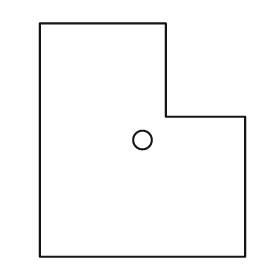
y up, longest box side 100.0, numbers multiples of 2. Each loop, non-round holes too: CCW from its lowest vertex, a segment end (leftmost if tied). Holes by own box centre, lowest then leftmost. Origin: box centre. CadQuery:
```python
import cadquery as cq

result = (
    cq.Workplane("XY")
    .moveTo(-44.0, -50.0)
    .lineTo(44.0, -50.0)
    .lineTo(44.0, 10.0)
    .lineTo(10.0, 10.0)
    .lineTo(10.0, 50.0)
    .lineTo(-44.0, 50.0)
    .close()
    .moveTo(0.0, 0.0)
    .circle(4.0)
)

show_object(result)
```